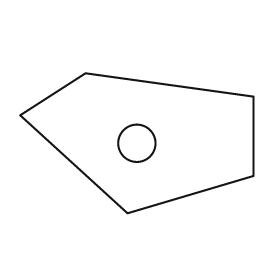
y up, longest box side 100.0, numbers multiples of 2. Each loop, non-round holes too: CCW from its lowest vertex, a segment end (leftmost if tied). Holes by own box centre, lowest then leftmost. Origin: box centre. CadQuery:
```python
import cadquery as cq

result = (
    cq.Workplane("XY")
    .moveTo(-4.0, -30.0)
    .lineTo(50.0, -14.0)
    .lineTo(50.0, 20.0)
    .lineTo(-22.0, 30.0)
    .lineTo(-50.0, 12.0)
    .close()
    .moveTo(0.0, 0.0)
    .circle(8.0)
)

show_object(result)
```